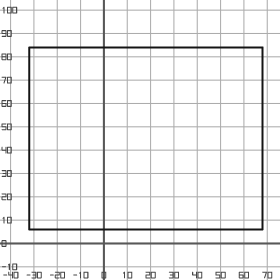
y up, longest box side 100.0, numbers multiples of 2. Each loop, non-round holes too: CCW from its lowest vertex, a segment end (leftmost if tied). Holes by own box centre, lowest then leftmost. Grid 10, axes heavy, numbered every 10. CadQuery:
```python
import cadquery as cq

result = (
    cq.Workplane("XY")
    .moveTo(-32.0, 6.0)
    .lineTo(68.0, 6.0)
    .lineTo(68.0, 84.0)
    .lineTo(-32.0, 84.0)
    .close()
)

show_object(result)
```